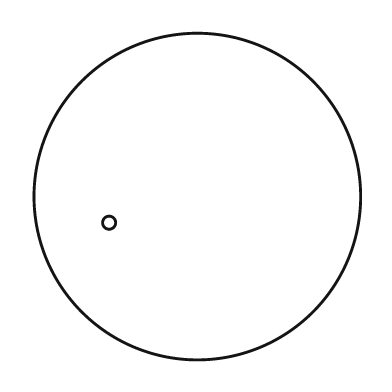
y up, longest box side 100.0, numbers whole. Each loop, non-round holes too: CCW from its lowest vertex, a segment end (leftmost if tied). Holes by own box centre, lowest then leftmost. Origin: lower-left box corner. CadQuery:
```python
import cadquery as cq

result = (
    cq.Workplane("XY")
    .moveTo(50.0, 50.0)
    .circle(50.0)
    .moveTo(23.0, 42.0)
    .circle(2.0)
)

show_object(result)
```